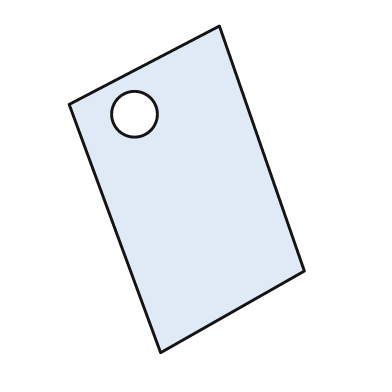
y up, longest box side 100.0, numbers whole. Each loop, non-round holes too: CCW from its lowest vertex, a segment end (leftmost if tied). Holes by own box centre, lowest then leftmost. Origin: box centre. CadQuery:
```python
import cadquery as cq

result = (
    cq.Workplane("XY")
    .moveTo(-8.0, -50.0)
    .lineTo(36.0, -25.0)
    .lineTo(10.0, 50.0)
    .lineTo(-36.0, 26.0)
    .close()
    .moveTo(-16.0, 23.0)
    .circle(7.0)
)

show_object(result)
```